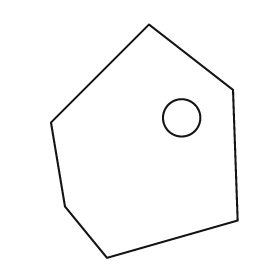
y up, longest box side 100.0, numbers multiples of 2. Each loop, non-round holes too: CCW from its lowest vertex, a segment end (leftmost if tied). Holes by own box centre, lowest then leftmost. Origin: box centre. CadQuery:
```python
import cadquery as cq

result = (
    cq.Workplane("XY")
    .moveTo(-16.0, -50.0)
    .lineTo(40.0, -34.0)
    .lineTo(38.0, 22.0)
    .lineTo(2.0, 50.0)
    .lineTo(-40.0, 8.0)
    .lineTo(-34.0, -28.0)
    .close()
    .moveTo(16.0, 10.0)
    .circle(8.0)
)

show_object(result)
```